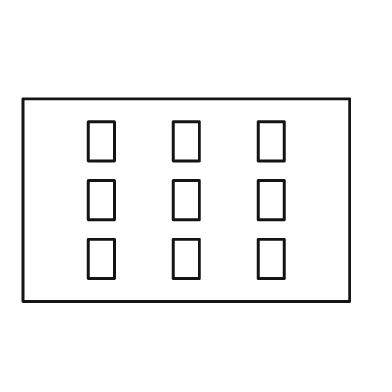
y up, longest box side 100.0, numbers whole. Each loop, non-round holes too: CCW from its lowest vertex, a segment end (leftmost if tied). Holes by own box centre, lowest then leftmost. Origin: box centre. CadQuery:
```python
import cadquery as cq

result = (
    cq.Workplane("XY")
    .moveTo(-50.0, -31.0)
    .lineTo(50.0, -31.0)
    .lineTo(50.0, 31.0)
    .lineTo(-50.0, 31.0)
    .close()
    .moveTo(-30.0, -24.0)
    .lineTo(-22.0, -24.0)
    .lineTo(-22.0, -12.0)
    .lineTo(-30.0, -12.0)
    .close()
    .moveTo(-4.0, -24.0)
    .lineTo(4.0, -24.0)
    .lineTo(4.0, -12.0)
    .lineTo(-4.0, -12.0)
    .close()
    .moveTo(22.0, -24.0)
    .lineTo(30.0, -24.0)
    .lineTo(30.0, -12.0)
    .lineTo(22.0, -12.0)
    .close()
    .moveTo(-30.0, -6.0)
    .lineTo(-22.0, -6.0)
    .lineTo(-22.0, 6.0)
    .lineTo(-30.0, 6.0)
    .close()
    .moveTo(-4.0, -6.0)
    .lineTo(4.0, -6.0)
    .lineTo(4.0, 6.0)
    .lineTo(-4.0, 6.0)
    .close()
    .moveTo(22.0, -6.0)
    .lineTo(30.0, -6.0)
    .lineTo(30.0, 6.0)
    .lineTo(22.0, 6.0)
    .close()
    .moveTo(-30.0, 12.0)
    .lineTo(-22.0, 12.0)
    .lineTo(-22.0, 24.0)
    .lineTo(-30.0, 24.0)
    .close()
    .moveTo(-4.0, 12.0)
    .lineTo(4.0, 12.0)
    .lineTo(4.0, 24.0)
    .lineTo(-4.0, 24.0)
    .close()
    .moveTo(22.0, 12.0)
    .lineTo(30.0, 12.0)
    .lineTo(30.0, 24.0)
    .lineTo(22.0, 24.0)
    .close()
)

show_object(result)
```